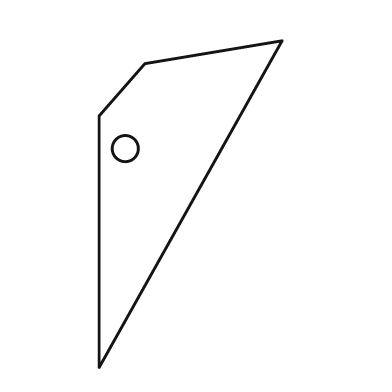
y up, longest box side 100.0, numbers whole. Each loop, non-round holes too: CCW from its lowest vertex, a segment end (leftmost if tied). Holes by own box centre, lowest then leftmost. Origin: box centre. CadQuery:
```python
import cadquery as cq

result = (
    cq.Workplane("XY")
    .moveTo(-28.0, -50.0)
    .lineTo(28.0, 50.0)
    .lineTo(-14.0, 43.0)
    .lineTo(-28.0, 27.0)
    .close()
    .moveTo(-20.0, 17.0)
    .circle(4.0)
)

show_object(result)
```